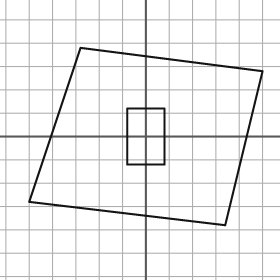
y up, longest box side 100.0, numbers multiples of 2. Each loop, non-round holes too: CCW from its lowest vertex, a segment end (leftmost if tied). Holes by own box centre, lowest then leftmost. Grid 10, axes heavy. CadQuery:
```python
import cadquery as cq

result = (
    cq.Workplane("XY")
    .moveTo(34.0, -38.0)
    .lineTo(50.0, 28.0)
    .lineTo(-28.0, 38.0)
    .lineTo(-50.0, -28.0)
    .close()
    .moveTo(-8.0, -12.0)
    .lineTo(8.0, -12.0)
    .lineTo(8.0, 12.0)
    .lineTo(-8.0, 12.0)
    .close()
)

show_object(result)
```